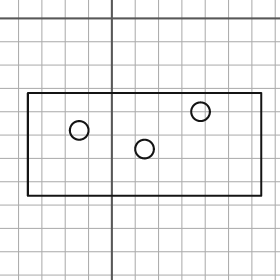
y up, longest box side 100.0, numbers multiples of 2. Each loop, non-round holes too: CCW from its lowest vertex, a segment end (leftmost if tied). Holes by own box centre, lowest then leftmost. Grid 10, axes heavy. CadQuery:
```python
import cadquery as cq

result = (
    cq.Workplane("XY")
    .moveTo(-36.0, -76.0)
    .lineTo(64.0, -76.0)
    .lineTo(64.0, -32.0)
    .lineTo(-36.0, -32.0)
    .close()
    .moveTo(14.0, -56.0)
    .circle(4.0)
    .moveTo(-14.0, -48.0)
    .circle(4.0)
    .moveTo(38.0, -40.0)
    .circle(4.0)
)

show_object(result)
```